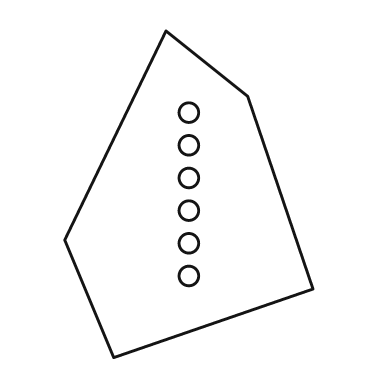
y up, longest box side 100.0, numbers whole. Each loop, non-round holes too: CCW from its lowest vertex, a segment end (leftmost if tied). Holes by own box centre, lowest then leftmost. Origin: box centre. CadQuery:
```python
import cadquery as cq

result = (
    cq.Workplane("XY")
    .moveTo(-23.0, -50.0)
    .lineTo(38.0, -29.0)
    .lineTo(18.0, 30.0)
    .lineTo(-7.0, 50.0)
    .lineTo(-38.0, -14.0)
    .close()
    .moveTo(0.0, -25.0)
    .circle(3.0)
    .moveTo(0.0, -15.0)
    .circle(3.0)
    .moveTo(0.0, -5.0)
    .circle(3.0)
    .moveTo(0.0, 5.0)
    .circle(3.0)
    .moveTo(0.0, 15.0)
    .circle(3.0)
    .moveTo(0.0, 25.0)
    .circle(3.0)
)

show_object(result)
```